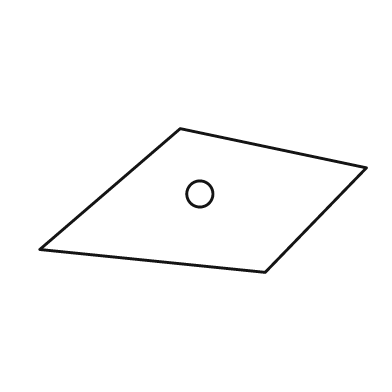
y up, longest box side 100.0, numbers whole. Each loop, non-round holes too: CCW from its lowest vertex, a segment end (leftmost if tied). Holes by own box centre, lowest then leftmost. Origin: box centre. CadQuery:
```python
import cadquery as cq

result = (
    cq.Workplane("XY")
    .moveTo(19.0, -22.0)
    .lineTo(50.0, 10.0)
    .lineTo(-7.0, 22.0)
    .lineTo(-50.0, -15.0)
    .close()
    .moveTo(-1.0, 2.0)
    .circle(4.0)
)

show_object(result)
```